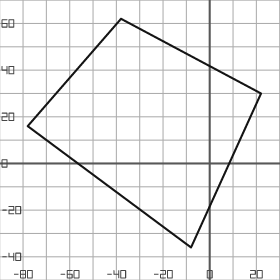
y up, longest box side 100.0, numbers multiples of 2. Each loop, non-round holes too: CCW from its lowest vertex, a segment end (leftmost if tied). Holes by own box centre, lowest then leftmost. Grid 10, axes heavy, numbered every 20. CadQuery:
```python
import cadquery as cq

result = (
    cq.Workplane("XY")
    .moveTo(-8.0, -36.0)
    .lineTo(22.0, 30.0)
    .lineTo(-38.0, 62.0)
    .lineTo(-78.0, 16.0)
    .close()
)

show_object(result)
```